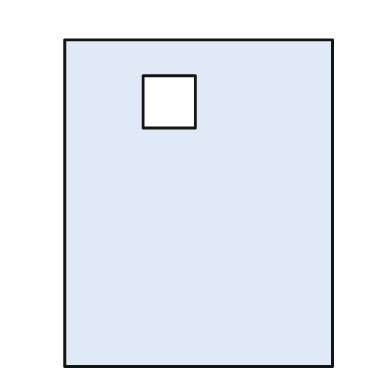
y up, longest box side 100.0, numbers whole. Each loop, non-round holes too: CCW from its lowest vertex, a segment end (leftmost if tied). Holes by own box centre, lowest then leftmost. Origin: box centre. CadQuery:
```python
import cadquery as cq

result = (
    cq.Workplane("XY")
    .moveTo(-41.0, -50.0)
    .lineTo(41.0, -50.0)
    .lineTo(41.0, 50.0)
    .lineTo(-41.0, 50.0)
    .close()
    .moveTo(-17.0, 23.0)
    .lineTo(-1.0, 23.0)
    .lineTo(-1.0, 39.0)
    .lineTo(-17.0, 39.0)
    .close()
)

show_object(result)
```